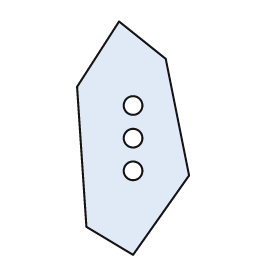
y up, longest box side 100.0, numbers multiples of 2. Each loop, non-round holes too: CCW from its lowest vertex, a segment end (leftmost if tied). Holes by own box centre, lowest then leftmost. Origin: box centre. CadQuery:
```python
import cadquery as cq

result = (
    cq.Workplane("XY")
    .moveTo(0.0, -50.0)
    .lineTo(24.0, -16.0)
    .lineTo(14.0, 34.0)
    .lineTo(-6.0, 50.0)
    .lineTo(-24.0, 22.0)
    .lineTo(-20.0, -38.0)
    .close()
    .moveTo(0.0, -14.0)
    .circle(4.0)
    .moveTo(0.0, 0.0)
    .circle(4.0)
    .moveTo(0.0, 14.0)
    .circle(4.0)
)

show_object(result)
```